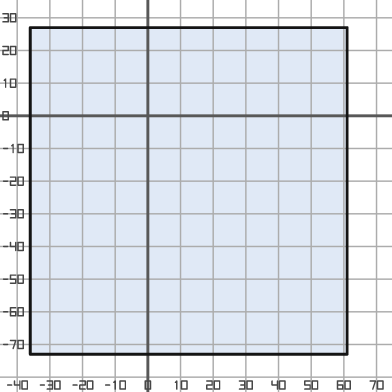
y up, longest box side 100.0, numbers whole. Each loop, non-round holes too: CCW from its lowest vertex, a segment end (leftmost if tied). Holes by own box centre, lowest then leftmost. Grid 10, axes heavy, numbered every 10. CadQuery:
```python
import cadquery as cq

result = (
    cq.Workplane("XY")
    .moveTo(-36.0, -73.0)
    .lineTo(61.0, -73.0)
    .lineTo(61.0, 27.0)
    .lineTo(-36.0, 27.0)
    .close()
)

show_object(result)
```